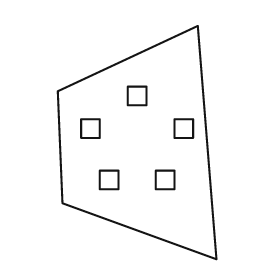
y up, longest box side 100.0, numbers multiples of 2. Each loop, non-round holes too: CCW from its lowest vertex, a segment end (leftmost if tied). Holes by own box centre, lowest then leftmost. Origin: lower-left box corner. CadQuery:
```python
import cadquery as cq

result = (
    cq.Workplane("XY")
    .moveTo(68.0, 0.0)
    .lineTo(60.0, 100.0)
    .lineTo(0.0, 72.0)
    .lineTo(2.0, 24.0)
    .close()
    .moveTo(18.0, 30.0)
    .lineTo(26.0, 30.0)
    .lineTo(26.0, 38.0)
    .lineTo(18.0, 38.0)
    .close()
    .moveTo(42.0, 30.0)
    .lineTo(50.0, 30.0)
    .lineTo(50.0, 38.0)
    .lineTo(42.0, 38.0)
    .close()
    .moveTo(10.0, 52.0)
    .lineTo(18.0, 52.0)
    .lineTo(18.0, 60.0)
    .lineTo(10.0, 60.0)
    .close()
    .moveTo(50.0, 52.0)
    .lineTo(58.0, 52.0)
    .lineTo(58.0, 60.0)
    .lineTo(50.0, 60.0)
    .close()
    .moveTo(30.0, 66.0)
    .lineTo(38.0, 66.0)
    .lineTo(38.0, 74.0)
    .lineTo(30.0, 74.0)
    .close()
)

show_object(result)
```